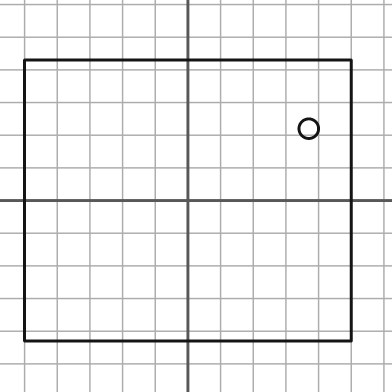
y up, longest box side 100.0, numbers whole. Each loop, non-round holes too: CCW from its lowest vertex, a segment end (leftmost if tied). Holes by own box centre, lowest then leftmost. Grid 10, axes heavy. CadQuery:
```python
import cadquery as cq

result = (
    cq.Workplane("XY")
    .moveTo(-50.0, -43.0)
    .lineTo(50.0, -43.0)
    .lineTo(50.0, 43.0)
    .lineTo(-50.0, 43.0)
    .close()
    .moveTo(37.0, 22.0)
    .circle(3.0)
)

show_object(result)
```